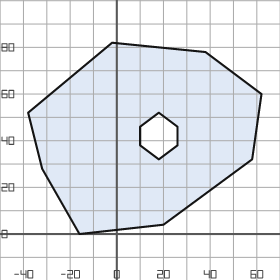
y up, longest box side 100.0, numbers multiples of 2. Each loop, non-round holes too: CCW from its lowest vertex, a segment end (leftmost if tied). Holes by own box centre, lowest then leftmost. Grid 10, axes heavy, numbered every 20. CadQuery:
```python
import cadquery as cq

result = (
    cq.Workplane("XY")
    .moveTo(-16.0, 0.0)
    .lineTo(20.0, 4.0)
    .lineTo(58.0, 32.0)
    .lineTo(62.0, 60.0)
    .lineTo(38.0, 78.0)
    .lineTo(-2.0, 82.0)
    .lineTo(-38.0, 52.0)
    .lineTo(-32.0, 28.0)
    .close()
    .moveTo(18.0, 32.0)
    .lineTo(26.0, 38.0)
    .lineTo(26.0, 46.0)
    .lineTo(18.0, 52.0)
    .lineTo(10.0, 46.0)
    .lineTo(10.0, 38.0)
    .close()
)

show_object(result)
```